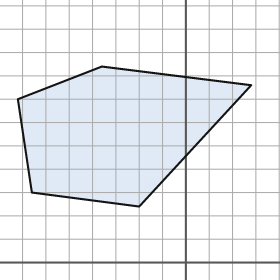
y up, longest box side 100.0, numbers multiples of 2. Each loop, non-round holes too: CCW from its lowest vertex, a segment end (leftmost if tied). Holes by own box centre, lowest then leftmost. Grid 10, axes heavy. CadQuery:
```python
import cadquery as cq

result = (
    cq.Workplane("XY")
    .moveTo(-20.0, 24.0)
    .lineTo(28.0, 76.0)
    .lineTo(-36.0, 84.0)
    .lineTo(-72.0, 70.0)
    .lineTo(-66.0, 30.0)
    .close()
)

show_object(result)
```